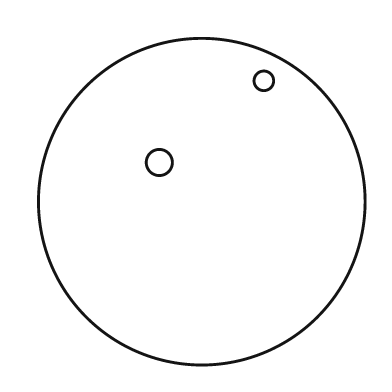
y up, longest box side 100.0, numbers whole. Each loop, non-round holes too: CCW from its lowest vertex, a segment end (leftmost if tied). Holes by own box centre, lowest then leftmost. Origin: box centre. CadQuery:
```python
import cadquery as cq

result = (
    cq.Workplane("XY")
    .moveTo(0.0, 0.0)
    .circle(50.0)
    .moveTo(-13.0, 12.0)
    .circle(4.0)
    .moveTo(19.0, 37.0)
    .circle(3.0)
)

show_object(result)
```